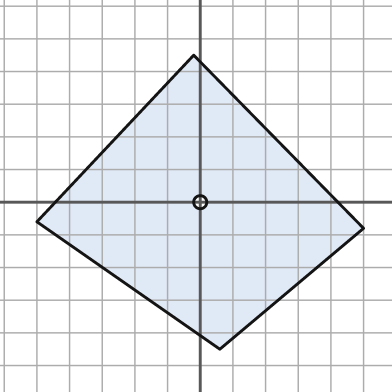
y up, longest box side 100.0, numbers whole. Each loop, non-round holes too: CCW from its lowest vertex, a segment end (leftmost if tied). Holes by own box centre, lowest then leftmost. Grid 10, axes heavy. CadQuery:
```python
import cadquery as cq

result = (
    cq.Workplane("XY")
    .moveTo(6.0, -45.0)
    .lineTo(50.0, -8.0)
    .lineTo(-2.0, 45.0)
    .lineTo(-50.0, -6.0)
    .close()
    .moveTo(0.0, 0.0)
    .circle(2.0)
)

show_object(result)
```